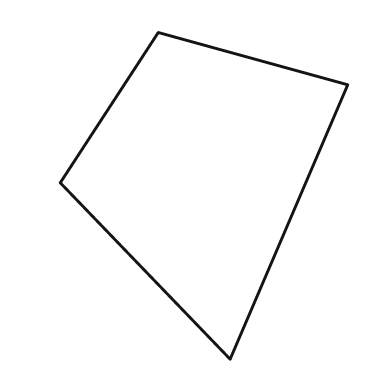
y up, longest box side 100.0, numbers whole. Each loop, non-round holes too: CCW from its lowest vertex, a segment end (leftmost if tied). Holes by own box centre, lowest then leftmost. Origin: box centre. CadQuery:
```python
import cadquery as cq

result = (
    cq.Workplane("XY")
    .moveTo(8.0, -50.0)
    .lineTo(44.0, 34.0)
    .lineTo(-14.0, 50.0)
    .lineTo(-44.0, 4.0)
    .close()
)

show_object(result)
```